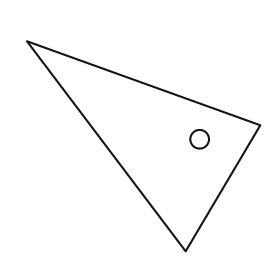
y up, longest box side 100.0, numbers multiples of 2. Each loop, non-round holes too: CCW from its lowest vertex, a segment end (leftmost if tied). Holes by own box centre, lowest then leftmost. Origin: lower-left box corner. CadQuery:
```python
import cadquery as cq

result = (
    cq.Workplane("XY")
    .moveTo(68.0, 0.0)
    .lineTo(100.0, 54.0)
    .lineTo(0.0, 90.0)
    .close()
    .moveTo(74.0, 48.0)
    .circle(4.0)
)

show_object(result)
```